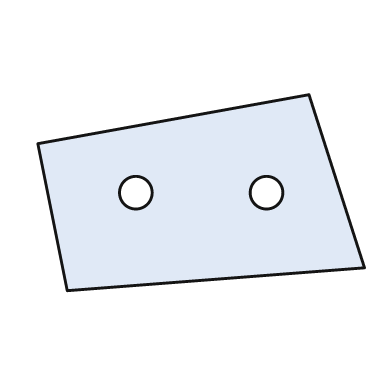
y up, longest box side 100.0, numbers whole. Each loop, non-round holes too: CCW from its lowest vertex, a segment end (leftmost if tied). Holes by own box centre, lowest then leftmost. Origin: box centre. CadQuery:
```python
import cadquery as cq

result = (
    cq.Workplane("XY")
    .moveTo(-41.0, -30.0)
    .lineTo(50.0, -23.0)
    .lineTo(33.0, 30.0)
    .lineTo(-50.0, 15.0)
    .close()
    .moveTo(-20.0, 0.0)
    .circle(5.0)
    .moveTo(20.0, 0.0)
    .circle(5.0)
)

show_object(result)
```